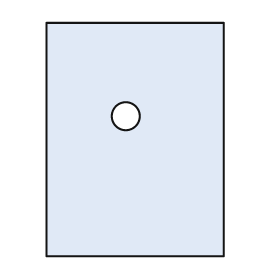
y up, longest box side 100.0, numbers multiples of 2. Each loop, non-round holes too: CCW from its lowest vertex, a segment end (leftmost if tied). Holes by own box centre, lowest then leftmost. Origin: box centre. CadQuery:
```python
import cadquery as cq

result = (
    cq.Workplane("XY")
    .moveTo(-38.0, -50.0)
    .lineTo(38.0, -50.0)
    .lineTo(38.0, 50.0)
    .lineTo(-38.0, 50.0)
    .close()
    .moveTo(-4.0, 10.0)
    .circle(6.0)
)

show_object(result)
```